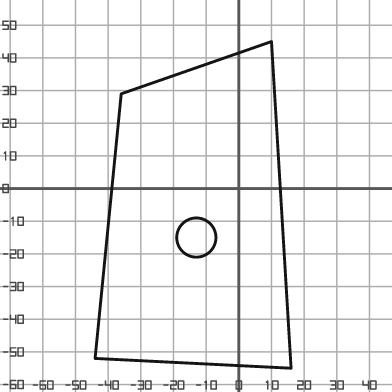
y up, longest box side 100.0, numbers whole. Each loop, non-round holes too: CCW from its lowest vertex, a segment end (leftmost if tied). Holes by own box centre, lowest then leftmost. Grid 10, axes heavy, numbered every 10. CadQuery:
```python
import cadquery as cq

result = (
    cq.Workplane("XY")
    .moveTo(16.0, -55.0)
    .lineTo(10.0, 45.0)
    .lineTo(-36.0, 29.0)
    .lineTo(-44.0, -52.0)
    .close()
    .moveTo(-13.0, -15.0)
    .circle(6.0)
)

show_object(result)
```